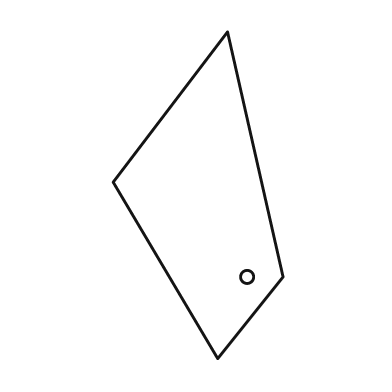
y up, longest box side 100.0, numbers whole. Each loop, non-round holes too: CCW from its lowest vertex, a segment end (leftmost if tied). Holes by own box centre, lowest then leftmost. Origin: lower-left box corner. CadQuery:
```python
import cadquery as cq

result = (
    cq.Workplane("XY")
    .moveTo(32.0, 0.0)
    .lineTo(52.0, 25.0)
    .lineTo(35.0, 100.0)
    .lineTo(0.0, 54.0)
    .close()
    .moveTo(41.0, 25.0)
    .circle(2.0)
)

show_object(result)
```